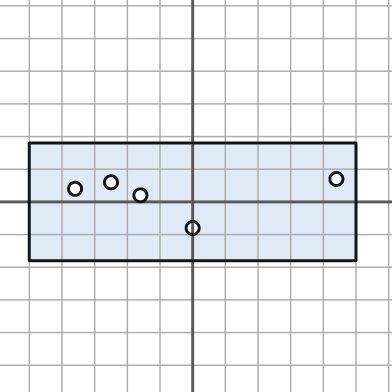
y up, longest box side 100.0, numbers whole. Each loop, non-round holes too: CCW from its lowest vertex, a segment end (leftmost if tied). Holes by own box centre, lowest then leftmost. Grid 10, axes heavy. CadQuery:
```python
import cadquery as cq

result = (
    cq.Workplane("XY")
    .moveTo(-50.0, -18.0)
    .lineTo(50.0, -18.0)
    .lineTo(50.0, 18.0)
    .lineTo(-50.0, 18.0)
    .close()
    .moveTo(0.0, -8.0)
    .circle(2.0)
    .moveTo(-16.0, 2.0)
    .circle(2.0)
    .moveTo(-36.0, 4.0)
    .circle(2.0)
    .moveTo(-25.0, 6.0)
    .circle(2.0)
    .moveTo(44.0, 7.0)
    .circle(2.0)
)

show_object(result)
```